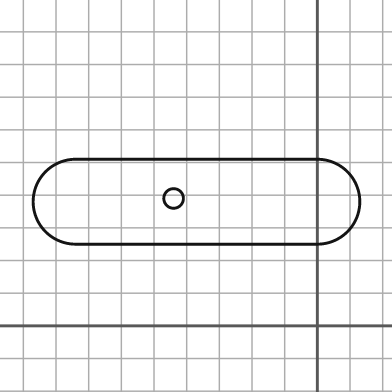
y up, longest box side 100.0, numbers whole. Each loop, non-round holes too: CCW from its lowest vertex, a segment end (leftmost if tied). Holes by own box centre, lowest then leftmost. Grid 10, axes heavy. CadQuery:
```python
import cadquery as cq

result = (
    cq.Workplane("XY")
    .moveTo(-74.0, 25.0)
    .lineTo(0.0, 25.0)
    .threePointArc((13.0, 38.0), (0.0, 51.0))
    .lineTo(-74.0, 51.0)
    .threePointArc((-87.0, 38.0), (-74.0, 25.0))
    .close()
    .moveTo(-44.0, 39.0)
    .circle(3.0)
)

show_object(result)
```